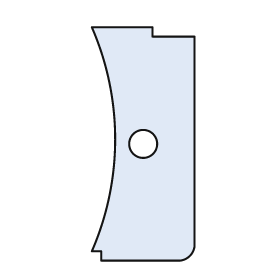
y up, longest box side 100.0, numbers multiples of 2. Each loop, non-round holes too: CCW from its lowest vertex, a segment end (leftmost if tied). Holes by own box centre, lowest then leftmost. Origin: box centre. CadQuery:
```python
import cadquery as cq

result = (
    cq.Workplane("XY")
    .moveTo(-18.0, -50.0)
    .lineTo(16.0, -50.0)
    .threePointArc((20.0, -48.0), (22.0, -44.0))
    .lineTo(22.0, 46.0)
    .lineTo(4.0, 46.0)
    .lineTo(4.0, 50.0)
    .lineTo(-22.0, 50.0)
    .threePointArc((-12.0, 2.0), (-22.0, -46.0))
    .lineTo(-18.0, -46.0)
    .close()
    .moveTo(0.0, 0.0)
    .circle(6.0)
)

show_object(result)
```